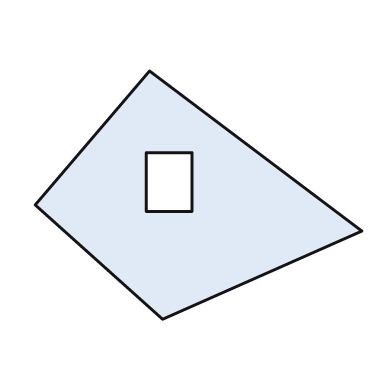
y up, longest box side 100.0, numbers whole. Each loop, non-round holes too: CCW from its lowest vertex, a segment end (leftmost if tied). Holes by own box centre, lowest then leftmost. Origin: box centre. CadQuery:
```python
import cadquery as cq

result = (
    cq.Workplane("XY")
    .moveTo(-11.0, -38.0)
    .lineTo(50.0, -11.0)
    .lineTo(-15.0, 38.0)
    .lineTo(-50.0, -3.0)
    .close()
    .moveTo(-16.0, -5.0)
    .lineTo(-2.0, -5.0)
    .lineTo(-2.0, 13.0)
    .lineTo(-16.0, 13.0)
    .close()
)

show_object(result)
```